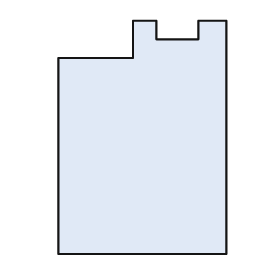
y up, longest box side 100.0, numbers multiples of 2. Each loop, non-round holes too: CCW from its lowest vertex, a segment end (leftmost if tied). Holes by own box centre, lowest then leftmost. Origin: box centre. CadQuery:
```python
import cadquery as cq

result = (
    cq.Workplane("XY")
    .moveTo(-36.0, -50.0)
    .lineTo(36.0, -50.0)
    .lineTo(36.0, 50.0)
    .lineTo(24.0, 50.0)
    .lineTo(24.0, 42.0)
    .lineTo(6.0, 42.0)
    .lineTo(6.0, 50.0)
    .lineTo(-4.0, 50.0)
    .lineTo(-4.0, 34.0)
    .lineTo(-36.0, 34.0)
    .close()
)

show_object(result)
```